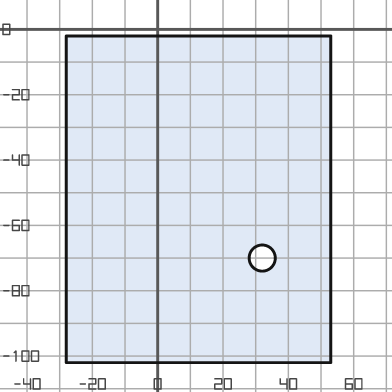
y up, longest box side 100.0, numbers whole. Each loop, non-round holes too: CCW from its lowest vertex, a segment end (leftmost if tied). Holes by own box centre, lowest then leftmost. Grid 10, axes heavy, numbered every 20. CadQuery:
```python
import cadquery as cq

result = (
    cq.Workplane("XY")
    .moveTo(-28.0, -102.0)
    .lineTo(53.0, -102.0)
    .lineTo(53.0, -2.0)
    .lineTo(-28.0, -2.0)
    .close()
    .moveTo(32.0, -70.0)
    .circle(4.0)
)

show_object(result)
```